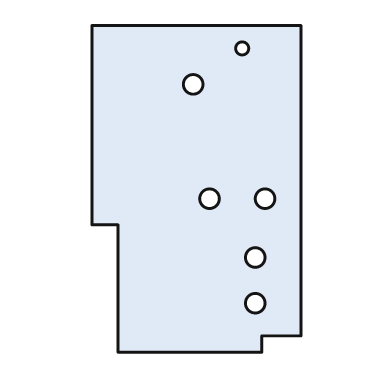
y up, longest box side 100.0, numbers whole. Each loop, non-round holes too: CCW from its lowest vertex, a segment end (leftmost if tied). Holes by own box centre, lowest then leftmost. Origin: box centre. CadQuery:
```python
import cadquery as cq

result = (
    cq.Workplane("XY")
    .moveTo(-24.0, -50.0)
    .lineTo(20.0, -50.0)
    .lineTo(20.0, -45.0)
    .lineTo(32.0, -45.0)
    .lineTo(32.0, 50.0)
    .lineTo(-32.0, 50.0)
    .lineTo(-32.0, -11.0)
    .lineTo(-24.0, -11.0)
    .close()
    .moveTo(18.0, -35.0)
    .circle(3.0)
    .moveTo(18.0, -21.0)
    .circle(3.0)
    .moveTo(4.0, -3.0)
    .circle(3.0)
    .moveTo(21.0, -3.0)
    .circle(3.0)
    .moveTo(-1.0, 32.0)
    .circle(3.0)
    .moveTo(14.0, 43.0)
    .circle(2.0)
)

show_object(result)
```